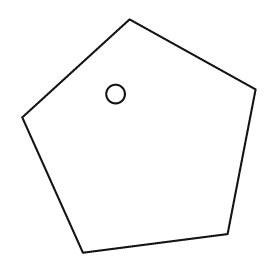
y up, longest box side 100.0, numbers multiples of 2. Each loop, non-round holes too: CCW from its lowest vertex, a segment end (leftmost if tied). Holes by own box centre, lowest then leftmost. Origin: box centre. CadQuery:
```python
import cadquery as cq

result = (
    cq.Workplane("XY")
    .moveTo(-24.0, -50.0)
    .lineTo(38.0, -42.0)
    .lineTo(50.0, 20.0)
    .lineTo(-4.0, 50.0)
    .lineTo(-50.0, 8.0)
    .close()
    .moveTo(-10.0, 18.0)
    .circle(4.0)
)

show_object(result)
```